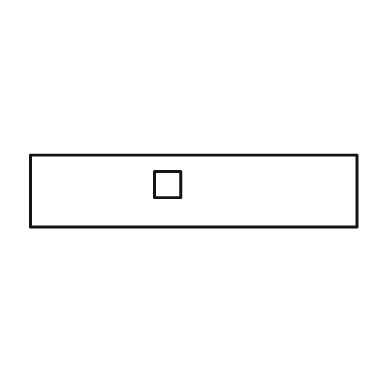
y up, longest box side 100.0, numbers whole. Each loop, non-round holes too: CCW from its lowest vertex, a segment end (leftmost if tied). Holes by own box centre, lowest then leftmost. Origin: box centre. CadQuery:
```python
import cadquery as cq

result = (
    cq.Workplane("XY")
    .moveTo(-50.0, -11.0)
    .lineTo(50.0, -11.0)
    .lineTo(50.0, 11.0)
    .lineTo(-50.0, 11.0)
    .close()
    .moveTo(-12.0, -2.0)
    .lineTo(-4.0, -2.0)
    .lineTo(-4.0, 6.0)
    .lineTo(-12.0, 6.0)
    .close()
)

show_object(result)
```